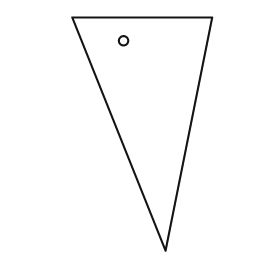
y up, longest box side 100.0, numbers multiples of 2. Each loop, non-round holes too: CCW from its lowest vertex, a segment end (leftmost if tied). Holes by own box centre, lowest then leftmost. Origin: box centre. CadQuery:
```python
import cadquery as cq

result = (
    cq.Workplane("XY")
    .moveTo(10.0, -50.0)
    .lineTo(30.0, 50.0)
    .lineTo(-30.0, 50.0)
    .close()
    .moveTo(-8.0, 40.0)
    .circle(2.0)
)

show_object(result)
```